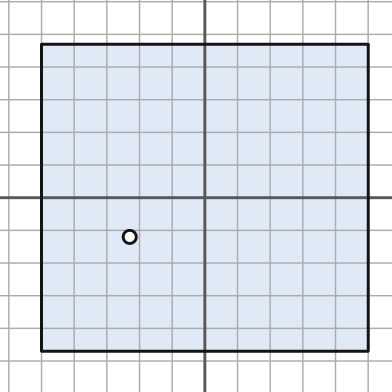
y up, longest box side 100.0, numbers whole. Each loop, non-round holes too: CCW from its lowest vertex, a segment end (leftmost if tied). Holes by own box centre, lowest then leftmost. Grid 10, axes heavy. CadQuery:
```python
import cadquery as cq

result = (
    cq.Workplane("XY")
    .moveTo(-50.0, -47.0)
    .lineTo(50.0, -47.0)
    .lineTo(50.0, 47.0)
    .lineTo(-50.0, 47.0)
    .close()
    .moveTo(-23.0, -12.0)
    .circle(2.0)
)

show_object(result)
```